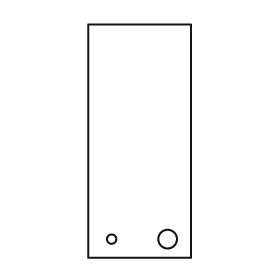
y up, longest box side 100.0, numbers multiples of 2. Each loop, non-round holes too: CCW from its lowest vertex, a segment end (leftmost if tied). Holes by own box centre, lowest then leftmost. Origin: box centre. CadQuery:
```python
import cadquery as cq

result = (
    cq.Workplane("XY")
    .moveTo(-22.0, -50.0)
    .lineTo(22.0, -50.0)
    .lineTo(22.0, 50.0)
    .lineTo(-22.0, 50.0)
    .close()
    .moveTo(-12.0, -42.0)
    .circle(2.0)
    .moveTo(12.0, -42.0)
    .circle(4.0)
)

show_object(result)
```